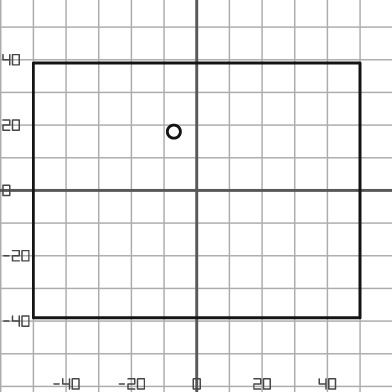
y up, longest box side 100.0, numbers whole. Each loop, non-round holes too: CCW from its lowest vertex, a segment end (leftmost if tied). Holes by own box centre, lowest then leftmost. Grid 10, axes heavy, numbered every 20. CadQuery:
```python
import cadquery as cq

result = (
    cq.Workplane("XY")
    .moveTo(-50.0, -39.0)
    .lineTo(50.0, -39.0)
    .lineTo(50.0, 39.0)
    .lineTo(-50.0, 39.0)
    .close()
    .moveTo(-7.0, 18.0)
    .circle(2.0)
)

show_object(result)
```